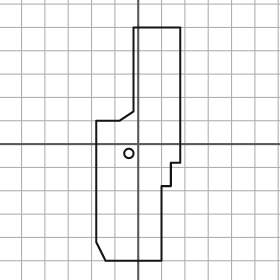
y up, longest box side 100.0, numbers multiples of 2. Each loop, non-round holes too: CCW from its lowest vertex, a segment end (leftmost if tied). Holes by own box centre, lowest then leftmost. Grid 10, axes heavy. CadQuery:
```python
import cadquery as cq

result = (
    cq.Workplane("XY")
    .moveTo(-14.0, -50.0)
    .lineTo(10.0, -50.0)
    .lineTo(10.0, -18.0)
    .lineTo(14.0, -18.0)
    .lineTo(14.0, -8.0)
    .lineTo(18.0, -8.0)
    .lineTo(18.0, 50.0)
    .lineTo(-2.0, 50.0)
    .lineTo(-2.0, 14.0)
    .lineTo(-8.0, 10.0)
    .lineTo(-18.0, 10.0)
    .lineTo(-18.0, -42.0)
    .close()
    .moveTo(-4.0, -4.0)
    .circle(2.0)
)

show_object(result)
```